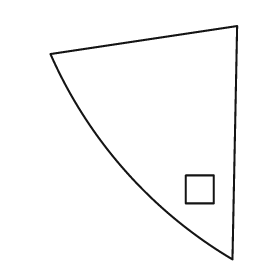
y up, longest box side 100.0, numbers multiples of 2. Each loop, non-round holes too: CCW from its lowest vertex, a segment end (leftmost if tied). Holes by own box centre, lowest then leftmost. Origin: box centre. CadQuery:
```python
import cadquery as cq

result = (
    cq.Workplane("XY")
    .moveTo(38.0, -50.0)
    .lineTo(40.0, 50.0)
    .lineTo(-40.0, 38.0)
    .threePointArc((-8.0, -12.0), (38.0, -50.0))
    .close()
    .moveTo(18.0, -26.0)
    .lineTo(30.0, -26.0)
    .lineTo(30.0, -14.0)
    .lineTo(18.0, -14.0)
    .close()
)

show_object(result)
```